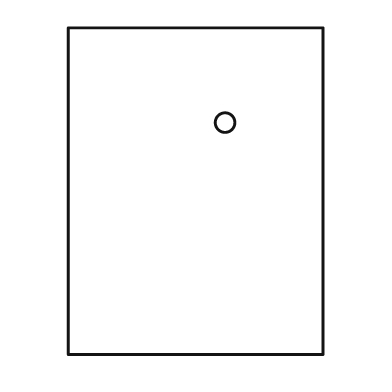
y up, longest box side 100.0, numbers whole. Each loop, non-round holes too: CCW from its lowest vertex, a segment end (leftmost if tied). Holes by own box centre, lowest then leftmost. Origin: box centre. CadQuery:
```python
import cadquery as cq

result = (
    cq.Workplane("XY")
    .moveTo(-39.0, -50.0)
    .lineTo(39.0, -50.0)
    .lineTo(39.0, 50.0)
    .lineTo(-39.0, 50.0)
    .close()
    .moveTo(9.0, 21.0)
    .circle(3.0)
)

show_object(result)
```